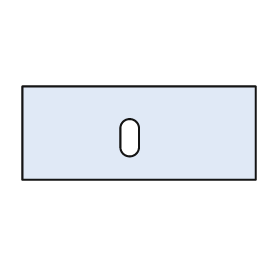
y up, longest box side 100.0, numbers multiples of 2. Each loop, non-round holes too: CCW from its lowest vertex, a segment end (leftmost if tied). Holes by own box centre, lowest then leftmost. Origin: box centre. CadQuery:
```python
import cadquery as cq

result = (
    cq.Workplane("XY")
    .moveTo(-50.0, -20.0)
    .lineTo(50.0, -20.0)
    .lineTo(50.0, 20.0)
    .lineTo(-50.0, 20.0)
    .close()
    .moveTo(-8.0, -6.0)
    .threePointArc((-4.0, -10.0), (0.0, -6.0))
    .lineTo(0.0, 2.0)
    .threePointArc((-4.0, 6.0), (-8.0, 2.0))
    .close()
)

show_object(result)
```